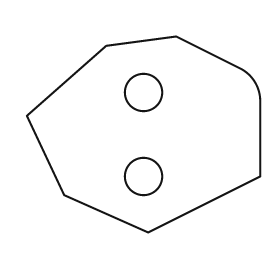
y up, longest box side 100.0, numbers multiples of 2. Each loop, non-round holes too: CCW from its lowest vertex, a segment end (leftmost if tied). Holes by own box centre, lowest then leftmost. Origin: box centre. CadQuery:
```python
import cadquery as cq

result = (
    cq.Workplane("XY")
    .moveTo(2.0, -42.0)
    .lineTo(50.0, -18.0)
    .lineTo(50.0, 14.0)
    .threePointArc((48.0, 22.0), (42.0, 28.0))
    .lineTo(14.0, 42.0)
    .lineTo(-16.0, 38.0)
    .lineTo(-50.0, 8.0)
    .lineTo(-34.0, -26.0)
    .close()
    .moveTo(0.0, -18.0)
    .circle(8.0)
    .moveTo(0.0, 18.0)
    .circle(8.0)
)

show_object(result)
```